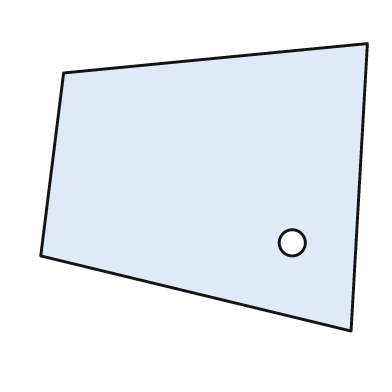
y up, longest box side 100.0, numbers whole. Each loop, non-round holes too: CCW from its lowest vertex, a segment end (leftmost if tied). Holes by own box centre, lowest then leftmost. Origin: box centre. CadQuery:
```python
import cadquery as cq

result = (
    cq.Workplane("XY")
    .moveTo(45.0, -44.0)
    .lineTo(50.0, 44.0)
    .lineTo(-43.0, 35.0)
    .lineTo(-50.0, -21.0)
    .close()
    .moveTo(27.0, -17.0)
    .circle(4.0)
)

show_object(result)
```